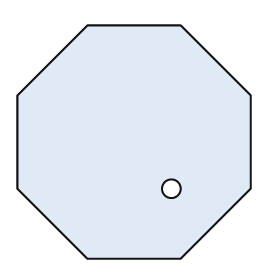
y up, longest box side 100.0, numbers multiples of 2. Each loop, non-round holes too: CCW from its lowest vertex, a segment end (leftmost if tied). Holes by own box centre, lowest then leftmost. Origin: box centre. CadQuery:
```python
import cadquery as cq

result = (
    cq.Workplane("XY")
    .moveTo(-20.0, -50.0)
    .lineTo(20.0, -50.0)
    .lineTo(50.0, -20.0)
    .lineTo(50.0, 20.0)
    .lineTo(20.0, 50.0)
    .lineTo(-20.0, 50.0)
    .lineTo(-50.0, 20.0)
    .lineTo(-50.0, -20.0)
    .close()
    .moveTo(16.0, -20.0)
    .circle(4.0)
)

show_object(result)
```